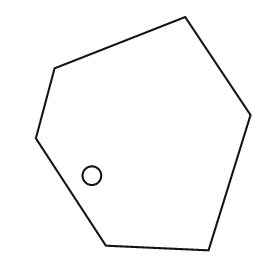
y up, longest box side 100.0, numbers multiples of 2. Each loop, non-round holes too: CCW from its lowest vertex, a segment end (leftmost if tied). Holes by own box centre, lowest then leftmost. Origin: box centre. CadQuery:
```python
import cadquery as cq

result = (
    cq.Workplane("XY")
    .moveTo(28.0, -50.0)
    .lineTo(46.0, 8.0)
    .lineTo(18.0, 50.0)
    .lineTo(-38.0, 28.0)
    .lineTo(-46.0, -2.0)
    .lineTo(-16.0, -48.0)
    .close()
    .moveTo(-22.0, -18.0)
    .circle(4.0)
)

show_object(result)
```